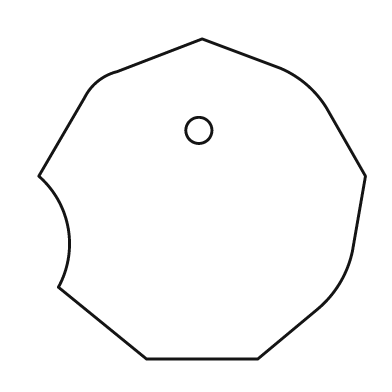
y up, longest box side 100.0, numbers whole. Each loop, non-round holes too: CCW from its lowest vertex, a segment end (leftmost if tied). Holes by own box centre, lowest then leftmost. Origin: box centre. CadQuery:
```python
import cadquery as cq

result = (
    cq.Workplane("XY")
    .moveTo(-17.0, -49.0)
    .lineTo(17.0, -49.0)
    .lineTo(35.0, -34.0)
    .threePointArc((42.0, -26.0), (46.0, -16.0))
    .lineTo(50.0, 7.0)
    .lineTo(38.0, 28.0)
    .threePointArc((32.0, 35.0), (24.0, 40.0))
    .lineTo(0.0, 49.0)
    .lineTo(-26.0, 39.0)
    .threePointArc((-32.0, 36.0), (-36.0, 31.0))
    .lineTo(-50.0, 7.0)
    .threePointArc((-41.0, -9.0), (-44.0, -27.0))
    .close()
    .moveTo(-1.0, 21.0)
    .circle(4.0)
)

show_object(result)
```